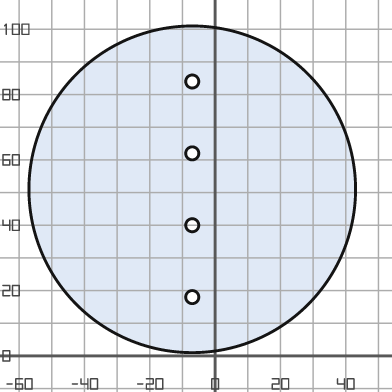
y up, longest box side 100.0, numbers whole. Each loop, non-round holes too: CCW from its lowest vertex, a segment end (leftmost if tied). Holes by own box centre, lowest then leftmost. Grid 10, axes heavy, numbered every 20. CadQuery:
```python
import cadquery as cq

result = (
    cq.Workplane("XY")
    .moveTo(-7.0, 51.0)
    .circle(50.0)
    .moveTo(-7.0, 18.0)
    .circle(2.0)
    .moveTo(-7.0, 40.0)
    .circle(2.0)
    .moveTo(-7.0, 62.0)
    .circle(2.0)
    .moveTo(-7.0, 84.0)
    .circle(2.0)
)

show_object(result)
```